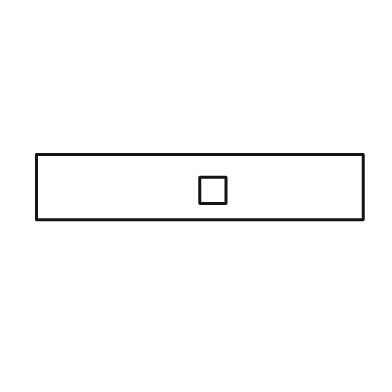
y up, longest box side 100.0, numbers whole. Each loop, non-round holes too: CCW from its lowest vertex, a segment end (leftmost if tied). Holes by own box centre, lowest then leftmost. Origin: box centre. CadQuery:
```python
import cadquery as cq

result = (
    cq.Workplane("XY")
    .moveTo(-50.0, -10.0)
    .lineTo(50.0, -10.0)
    .lineTo(50.0, 10.0)
    .lineTo(-50.0, 10.0)
    .close()
    .moveTo(0.0, -5.0)
    .lineTo(8.0, -5.0)
    .lineTo(8.0, 3.0)
    .lineTo(0.0, 3.0)
    .close()
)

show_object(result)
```